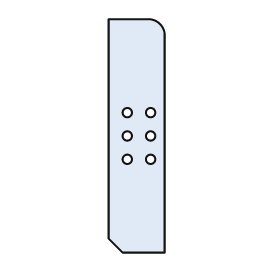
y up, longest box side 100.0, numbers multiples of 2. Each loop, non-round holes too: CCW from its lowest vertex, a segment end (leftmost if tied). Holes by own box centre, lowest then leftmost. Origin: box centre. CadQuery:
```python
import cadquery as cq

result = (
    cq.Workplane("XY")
    .moveTo(-6.0, -50.0)
    .lineTo(12.0, -50.0)
    .lineTo(12.0, 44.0)
    .threePointArc((10.0, 48.0), (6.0, 50.0))
    .lineTo(-12.0, 50.0)
    .lineTo(-12.0, -44.0)
    .close()
    .moveTo(-4.0, -10.0)
    .circle(2.0)
    .moveTo(6.0, -10.0)
    .circle(2.0)
    .moveTo(-4.0, 0.0)
    .circle(2.0)
    .moveTo(6.0, 0.0)
    .circle(2.0)
    .moveTo(-4.0, 10.0)
    .circle(2.0)
    .moveTo(6.0, 10.0)
    .circle(2.0)
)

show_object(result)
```